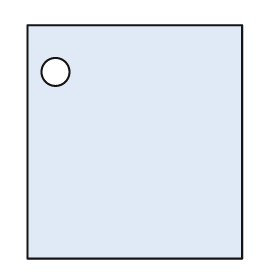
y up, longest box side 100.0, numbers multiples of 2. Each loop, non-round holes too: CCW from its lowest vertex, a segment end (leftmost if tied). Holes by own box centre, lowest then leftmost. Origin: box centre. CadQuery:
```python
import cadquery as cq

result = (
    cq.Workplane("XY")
    .moveTo(-46.0, -50.0)
    .lineTo(46.0, -50.0)
    .lineTo(46.0, 50.0)
    .lineTo(-46.0, 50.0)
    .close()
    .moveTo(-34.0, 30.0)
    .circle(6.0)
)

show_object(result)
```